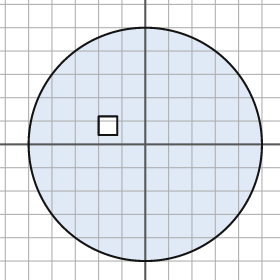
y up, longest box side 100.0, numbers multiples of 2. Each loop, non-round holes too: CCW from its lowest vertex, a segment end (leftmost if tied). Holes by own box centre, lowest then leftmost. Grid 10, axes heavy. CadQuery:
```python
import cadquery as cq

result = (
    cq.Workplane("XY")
    .moveTo(0.0, 0.0)
    .circle(50.0)
    .moveTo(-20.0, 4.0)
    .lineTo(-12.0, 4.0)
    .lineTo(-12.0, 12.0)
    .lineTo(-20.0, 12.0)
    .close()
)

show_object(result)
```